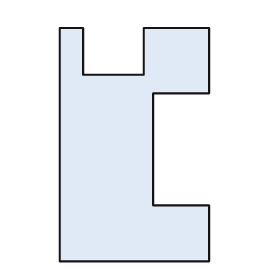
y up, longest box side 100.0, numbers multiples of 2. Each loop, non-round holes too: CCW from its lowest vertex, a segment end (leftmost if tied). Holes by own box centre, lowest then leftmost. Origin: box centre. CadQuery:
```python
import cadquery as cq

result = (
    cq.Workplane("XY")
    .moveTo(-32.0, -50.0)
    .lineTo(32.0, -50.0)
    .lineTo(32.0, -26.0)
    .lineTo(8.0, -26.0)
    .lineTo(8.0, 22.0)
    .lineTo(32.0, 22.0)
    .lineTo(32.0, 50.0)
    .lineTo(4.0, 50.0)
    .lineTo(4.0, 30.0)
    .lineTo(-22.0, 30.0)
    .lineTo(-22.0, 50.0)
    .lineTo(-32.0, 50.0)
    .close()
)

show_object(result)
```